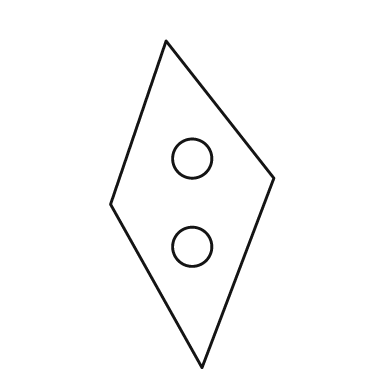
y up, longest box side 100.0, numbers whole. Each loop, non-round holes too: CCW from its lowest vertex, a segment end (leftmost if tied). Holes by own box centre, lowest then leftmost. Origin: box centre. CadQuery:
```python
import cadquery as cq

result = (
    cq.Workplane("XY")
    .moveTo(3.0, -50.0)
    .lineTo(25.0, 8.0)
    .lineTo(-8.0, 50.0)
    .lineTo(-25.0, 0.0)
    .close()
    .moveTo(0.0, -13.0)
    .circle(6.0)
    .moveTo(0.0, 14.0)
    .circle(6.0)
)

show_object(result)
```